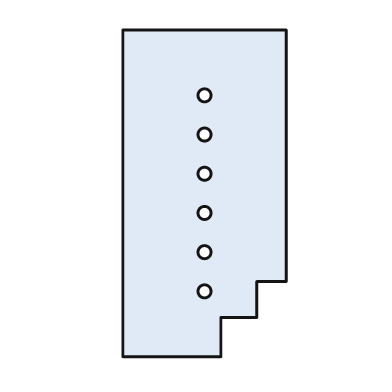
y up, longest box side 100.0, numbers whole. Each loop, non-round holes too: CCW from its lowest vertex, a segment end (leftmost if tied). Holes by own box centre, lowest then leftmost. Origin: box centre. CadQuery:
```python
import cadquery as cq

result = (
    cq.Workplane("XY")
    .moveTo(-25.0, -50.0)
    .lineTo(5.0, -50.0)
    .lineTo(5.0, -38.0)
    .lineTo(16.0, -38.0)
    .lineTo(16.0, -27.0)
    .lineTo(25.0, -27.0)
    .lineTo(25.0, 50.0)
    .lineTo(-25.0, 50.0)
    .close()
    .moveTo(0.0, -30.0)
    .circle(2.0)
    .moveTo(0.0, -18.0)
    .circle(2.0)
    .moveTo(0.0, -6.0)
    .circle(2.0)
    .moveTo(0.0, 6.0)
    .circle(2.0)
    .moveTo(0.0, 18.0)
    .circle(2.0)
    .moveTo(0.0, 30.0)
    .circle(2.0)
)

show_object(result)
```